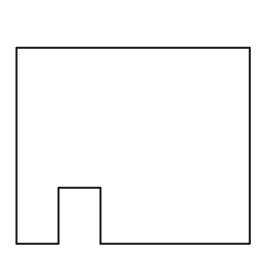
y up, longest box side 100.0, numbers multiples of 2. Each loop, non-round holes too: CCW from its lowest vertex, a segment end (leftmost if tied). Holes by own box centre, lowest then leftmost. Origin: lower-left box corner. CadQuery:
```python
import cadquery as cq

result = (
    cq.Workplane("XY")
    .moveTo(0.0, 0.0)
    .lineTo(18.0, 0.0)
    .lineTo(18.0, 24.0)
    .lineTo(36.0, 24.0)
    .lineTo(36.0, 0.0)
    .lineTo(100.0, 0.0)
    .lineTo(100.0, 84.0)
    .lineTo(0.0, 84.0)
    .close()
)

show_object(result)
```